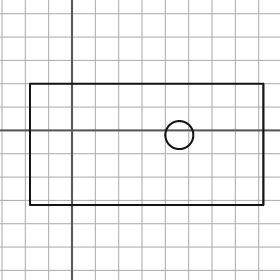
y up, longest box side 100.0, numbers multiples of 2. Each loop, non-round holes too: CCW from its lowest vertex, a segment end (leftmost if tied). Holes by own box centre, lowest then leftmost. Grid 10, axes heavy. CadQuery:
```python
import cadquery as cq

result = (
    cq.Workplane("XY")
    .moveTo(-18.0, -32.0)
    .lineTo(82.0, -32.0)
    .lineTo(82.0, 20.0)
    .lineTo(-18.0, 20.0)
    .close()
    .moveTo(46.0, -2.0)
    .circle(6.0)
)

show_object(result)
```